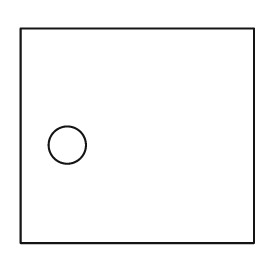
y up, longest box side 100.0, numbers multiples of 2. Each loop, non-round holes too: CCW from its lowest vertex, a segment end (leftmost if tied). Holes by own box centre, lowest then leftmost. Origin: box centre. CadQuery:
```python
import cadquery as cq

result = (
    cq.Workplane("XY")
    .moveTo(-50.0, -46.0)
    .lineTo(50.0, -46.0)
    .lineTo(50.0, 46.0)
    .lineTo(-50.0, 46.0)
    .close()
    .moveTo(-30.0, -4.0)
    .circle(8.0)
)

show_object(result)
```